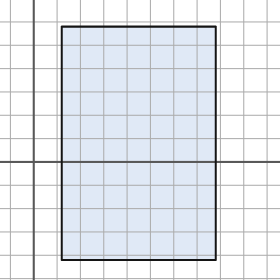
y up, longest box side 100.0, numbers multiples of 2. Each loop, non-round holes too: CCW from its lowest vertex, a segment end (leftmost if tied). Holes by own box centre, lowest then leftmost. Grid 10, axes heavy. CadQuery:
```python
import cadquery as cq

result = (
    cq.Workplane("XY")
    .moveTo(12.0, -42.0)
    .lineTo(78.0, -42.0)
    .lineTo(78.0, 58.0)
    .lineTo(12.0, 58.0)
    .close()
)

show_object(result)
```